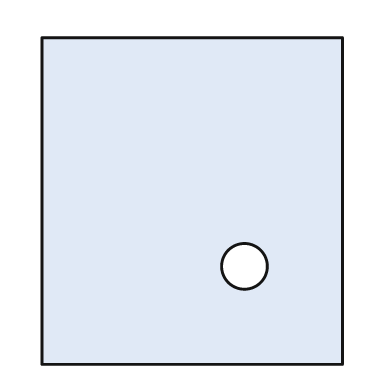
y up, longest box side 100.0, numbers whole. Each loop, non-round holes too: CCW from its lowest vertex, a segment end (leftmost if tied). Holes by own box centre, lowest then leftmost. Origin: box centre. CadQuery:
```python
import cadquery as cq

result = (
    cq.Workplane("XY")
    .moveTo(-46.0, -50.0)
    .lineTo(46.0, -50.0)
    .lineTo(46.0, 50.0)
    .lineTo(-46.0, 50.0)
    .close()
    .moveTo(16.0, -20.0)
    .circle(7.0)
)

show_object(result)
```